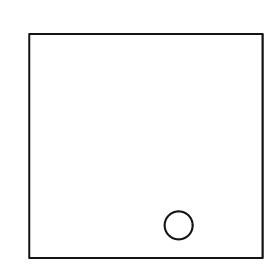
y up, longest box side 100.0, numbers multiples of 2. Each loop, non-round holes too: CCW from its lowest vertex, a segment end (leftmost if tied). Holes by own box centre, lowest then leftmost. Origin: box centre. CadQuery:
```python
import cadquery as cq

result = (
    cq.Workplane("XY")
    .moveTo(-50.0, -48.0)
    .lineTo(50.0, -48.0)
    .lineTo(50.0, 48.0)
    .lineTo(-50.0, 48.0)
    .close()
    .moveTo(14.0, -34.0)
    .circle(6.0)
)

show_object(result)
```